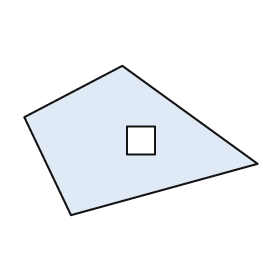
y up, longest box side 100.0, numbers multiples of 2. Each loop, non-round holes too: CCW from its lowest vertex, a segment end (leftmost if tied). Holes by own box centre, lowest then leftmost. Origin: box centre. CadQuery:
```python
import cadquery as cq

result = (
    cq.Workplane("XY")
    .moveTo(-30.0, -32.0)
    .lineTo(50.0, -10.0)
    .lineTo(-8.0, 32.0)
    .lineTo(-50.0, 10.0)
    .close()
    .moveTo(-6.0, -6.0)
    .lineTo(6.0, -6.0)
    .lineTo(6.0, 6.0)
    .lineTo(-6.0, 6.0)
    .close()
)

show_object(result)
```